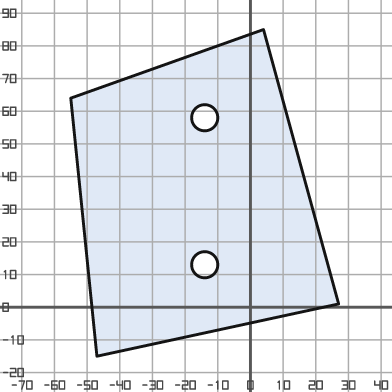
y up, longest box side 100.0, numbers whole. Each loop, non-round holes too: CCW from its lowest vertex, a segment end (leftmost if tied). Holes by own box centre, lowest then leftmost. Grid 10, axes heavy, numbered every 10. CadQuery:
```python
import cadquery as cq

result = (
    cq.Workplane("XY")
    .moveTo(-47.0, -15.0)
    .lineTo(27.0, 1.0)
    .lineTo(4.0, 85.0)
    .lineTo(-55.0, 64.0)
    .close()
    .moveTo(-14.0, 13.0)
    .circle(4.0)
    .moveTo(-14.0, 58.0)
    .circle(4.0)
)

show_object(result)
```